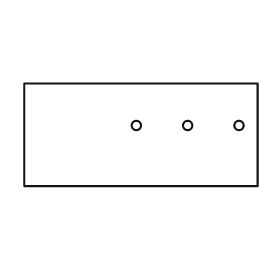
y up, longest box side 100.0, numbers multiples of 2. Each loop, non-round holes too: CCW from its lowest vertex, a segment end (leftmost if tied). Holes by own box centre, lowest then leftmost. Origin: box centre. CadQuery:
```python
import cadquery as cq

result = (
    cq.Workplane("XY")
    .moveTo(-50.0, -22.0)
    .lineTo(50.0, -22.0)
    .lineTo(50.0, 22.0)
    .lineTo(-50.0, 22.0)
    .close()
    .moveTo(-2.0, 4.0)
    .circle(2.0)
    .moveTo(20.0, 4.0)
    .circle(2.0)
    .moveTo(42.0, 4.0)
    .circle(2.0)
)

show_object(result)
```